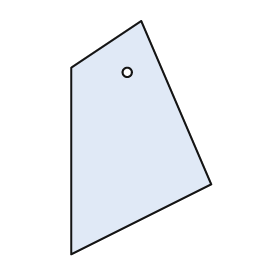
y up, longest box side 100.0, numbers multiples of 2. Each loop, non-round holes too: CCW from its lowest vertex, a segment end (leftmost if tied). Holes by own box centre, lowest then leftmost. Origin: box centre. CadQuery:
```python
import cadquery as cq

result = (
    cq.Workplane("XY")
    .moveTo(-30.0, -50.0)
    .lineTo(30.0, -20.0)
    .lineTo(0.0, 50.0)
    .lineTo(-30.0, 30.0)
    .close()
    .moveTo(-6.0, 28.0)
    .circle(2.0)
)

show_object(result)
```